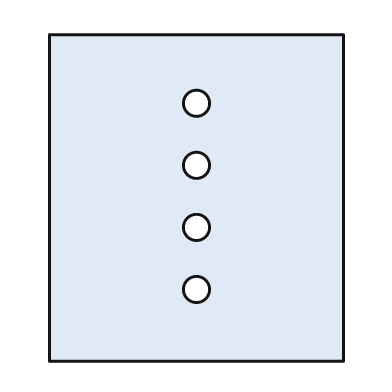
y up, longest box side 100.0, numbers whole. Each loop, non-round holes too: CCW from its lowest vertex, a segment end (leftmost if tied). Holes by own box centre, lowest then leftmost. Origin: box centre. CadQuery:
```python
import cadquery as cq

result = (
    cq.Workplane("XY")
    .moveTo(-45.0, -50.0)
    .lineTo(45.0, -50.0)
    .lineTo(45.0, 50.0)
    .lineTo(-45.0, 50.0)
    .close()
    .moveTo(0.0, -28.0)
    .circle(4.0)
    .moveTo(0.0, -9.0)
    .circle(4.0)
    .moveTo(0.0, 10.0)
    .circle(4.0)
    .moveTo(0.0, 29.0)
    .circle(4.0)
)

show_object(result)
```